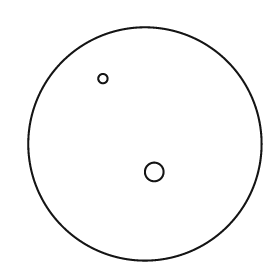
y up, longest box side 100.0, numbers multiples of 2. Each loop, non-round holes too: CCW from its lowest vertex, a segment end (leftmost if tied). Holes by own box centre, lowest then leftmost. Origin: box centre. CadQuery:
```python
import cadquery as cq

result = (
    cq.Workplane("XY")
    .moveTo(0.0, 0.0)
    .circle(50.0)
    .moveTo(4.0, -12.0)
    .circle(4.0)
    .moveTo(-18.0, 28.0)
    .circle(2.0)
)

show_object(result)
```